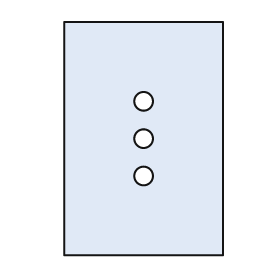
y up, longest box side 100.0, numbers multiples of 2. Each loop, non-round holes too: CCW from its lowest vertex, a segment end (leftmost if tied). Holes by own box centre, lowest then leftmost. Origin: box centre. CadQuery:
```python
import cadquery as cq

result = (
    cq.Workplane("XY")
    .moveTo(-34.0, -50.0)
    .lineTo(34.0, -50.0)
    .lineTo(34.0, 50.0)
    .lineTo(-34.0, 50.0)
    .close()
    .moveTo(0.0, -16.0)
    .circle(4.0)
    .moveTo(0.0, 0.0)
    .circle(4.0)
    .moveTo(0.0, 16.0)
    .circle(4.0)
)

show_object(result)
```